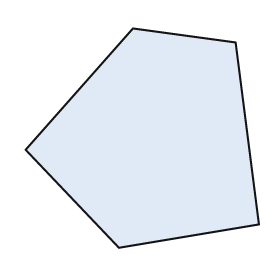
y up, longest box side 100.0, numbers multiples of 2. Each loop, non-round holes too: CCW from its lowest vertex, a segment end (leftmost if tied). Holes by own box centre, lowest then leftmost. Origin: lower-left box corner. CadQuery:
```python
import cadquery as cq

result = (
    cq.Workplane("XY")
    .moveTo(40.0, 0.0)
    .lineTo(100.0, 10.0)
    .lineTo(90.0, 88.0)
    .lineTo(46.0, 94.0)
    .lineTo(0.0, 42.0)
    .close()
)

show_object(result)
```